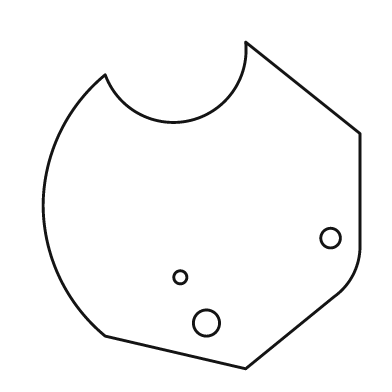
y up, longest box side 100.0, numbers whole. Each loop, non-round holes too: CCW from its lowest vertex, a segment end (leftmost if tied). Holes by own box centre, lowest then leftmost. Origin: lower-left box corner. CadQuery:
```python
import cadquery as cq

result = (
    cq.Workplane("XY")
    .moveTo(62.0, 0.0)
    .lineTo(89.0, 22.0)
    .threePointArc((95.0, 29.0), (97.0, 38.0))
    .lineTo(97.0, 72.0)
    .lineTo(62.0, 100.0)
    .threePointArc((45.0, 76.0), (19.0, 90.0))
    .threePointArc((5.0, 72.0), (0.0, 50.0))
    .threePointArc((5.0, 28.0), (19.0, 10.0))
    .close()
    .moveTo(50.0, 14.0)
    .circle(4.0)
    .moveTo(42.0, 28.0)
    .circle(2.0)
    .moveTo(88.0, 40.0)
    .circle(3.0)
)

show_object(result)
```